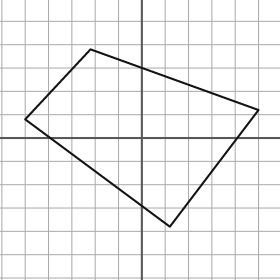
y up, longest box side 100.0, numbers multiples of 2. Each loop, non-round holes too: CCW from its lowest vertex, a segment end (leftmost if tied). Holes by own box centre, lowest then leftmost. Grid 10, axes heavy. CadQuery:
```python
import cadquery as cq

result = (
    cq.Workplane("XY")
    .moveTo(12.0, -38.0)
    .lineTo(50.0, 12.0)
    .lineTo(-22.0, 38.0)
    .lineTo(-50.0, 8.0)
    .close()
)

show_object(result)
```